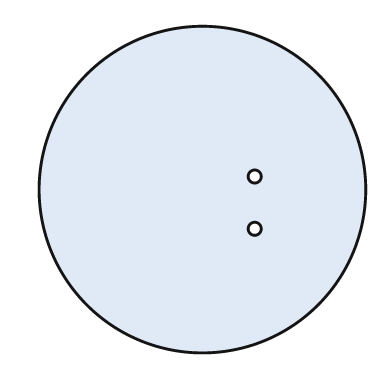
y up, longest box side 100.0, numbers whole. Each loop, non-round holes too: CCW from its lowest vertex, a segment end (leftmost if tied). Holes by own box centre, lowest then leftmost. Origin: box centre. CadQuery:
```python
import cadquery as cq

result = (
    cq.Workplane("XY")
    .moveTo(0.0, 0.0)
    .circle(50.0)
    .moveTo(16.0, -12.0)
    .circle(2.0)
    .moveTo(16.0, 4.0)
    .circle(2.0)
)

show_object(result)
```